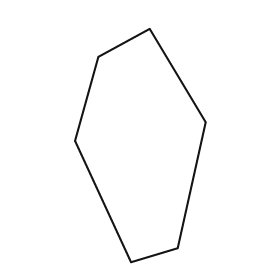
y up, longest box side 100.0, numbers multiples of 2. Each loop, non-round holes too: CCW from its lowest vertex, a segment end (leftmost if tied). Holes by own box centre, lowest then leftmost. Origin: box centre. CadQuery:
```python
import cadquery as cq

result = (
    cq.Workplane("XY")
    .moveTo(-4.0, -50.0)
    .lineTo(16.0, -44.0)
    .lineTo(28.0, 10.0)
    .lineTo(4.0, 50.0)
    .lineTo(-18.0, 38.0)
    .lineTo(-28.0, 2.0)
    .close()
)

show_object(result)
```